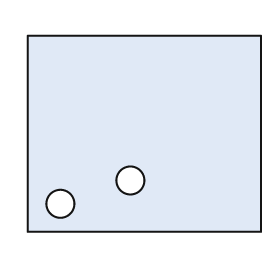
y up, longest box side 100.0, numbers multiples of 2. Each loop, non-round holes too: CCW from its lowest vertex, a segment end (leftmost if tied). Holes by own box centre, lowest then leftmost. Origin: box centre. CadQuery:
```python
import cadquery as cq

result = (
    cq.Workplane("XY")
    .moveTo(-50.0, -42.0)
    .lineTo(50.0, -42.0)
    .lineTo(50.0, 42.0)
    .lineTo(-50.0, 42.0)
    .close()
    .moveTo(-36.0, -30.0)
    .circle(6.0)
    .moveTo(-6.0, -20.0)
    .circle(6.0)
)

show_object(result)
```